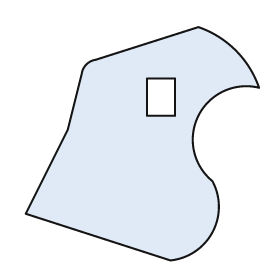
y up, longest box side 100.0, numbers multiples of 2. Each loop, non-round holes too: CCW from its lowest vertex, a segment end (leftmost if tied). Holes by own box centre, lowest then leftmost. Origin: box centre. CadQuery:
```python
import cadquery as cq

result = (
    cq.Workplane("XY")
    .moveTo(12.0, -50.0)
    .threePointArc((30.0, -38.0), (30.0, -16.0))
    .threePointArc((24.0, 12.0), (50.0, 24.0))
    .threePointArc((40.0, 40.0), (24.0, 50.0))
    .lineTo(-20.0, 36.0)
    .threePointArc((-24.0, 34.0), (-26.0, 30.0))
    .lineTo(-32.0, 6.0)
    .lineTo(-50.0, -30.0)
    .close()
    .moveTo(2.0, 12.0)
    .lineTo(14.0, 12.0)
    .lineTo(14.0, 28.0)
    .lineTo(2.0, 28.0)
    .close()
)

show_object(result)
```